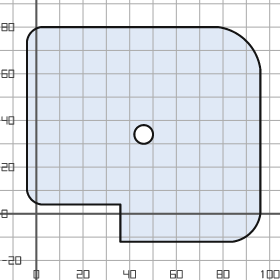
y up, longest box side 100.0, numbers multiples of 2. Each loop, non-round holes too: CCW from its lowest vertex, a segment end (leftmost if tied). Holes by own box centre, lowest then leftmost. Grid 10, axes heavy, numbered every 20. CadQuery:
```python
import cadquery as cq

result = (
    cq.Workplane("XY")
    .moveTo(36.0, -12.0)
    .lineTo(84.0, -12.0)
    .threePointArc((92.0, -8.0), (96.0, 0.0))
    .lineTo(96.0, 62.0)
    .threePointArc((90.0, 74.0), (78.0, 80.0))
    .lineTo(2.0, 80.0)
    .threePointArc((-2.0, 78.0), (-4.0, 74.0))
    .lineTo(-4.0, 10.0)
    .threePointArc((-2.0, 6.0), (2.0, 4.0))
    .lineTo(36.0, 4.0)
    .close()
    .moveTo(46.0, 34.0)
    .circle(4.0)
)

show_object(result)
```